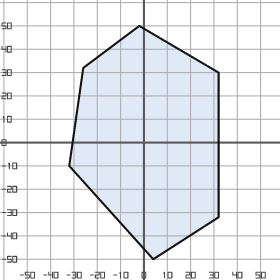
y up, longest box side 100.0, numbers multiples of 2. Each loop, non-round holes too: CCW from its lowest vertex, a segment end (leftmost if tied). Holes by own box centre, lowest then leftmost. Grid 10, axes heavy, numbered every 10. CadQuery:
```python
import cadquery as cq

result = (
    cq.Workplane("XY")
    .moveTo(4.0, -50.0)
    .lineTo(32.0, -32.0)
    .lineTo(32.0, 30.0)
    .lineTo(-2.0, 50.0)
    .lineTo(-26.0, 32.0)
    .lineTo(-32.0, -10.0)
    .close()
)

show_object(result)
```